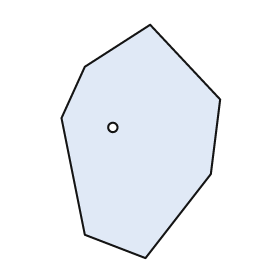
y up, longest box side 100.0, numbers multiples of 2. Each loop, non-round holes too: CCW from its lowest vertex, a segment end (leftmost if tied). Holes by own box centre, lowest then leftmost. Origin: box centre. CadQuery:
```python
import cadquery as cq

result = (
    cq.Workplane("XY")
    .moveTo(2.0, -50.0)
    .lineTo(30.0, -14.0)
    .lineTo(34.0, 18.0)
    .lineTo(4.0, 50.0)
    .lineTo(-24.0, 32.0)
    .lineTo(-34.0, 10.0)
    .lineTo(-24.0, -40.0)
    .close()
    .moveTo(-12.0, 6.0)
    .circle(2.0)
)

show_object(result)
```